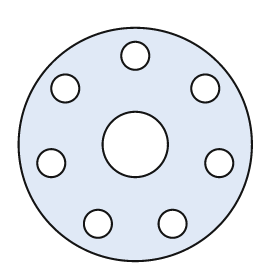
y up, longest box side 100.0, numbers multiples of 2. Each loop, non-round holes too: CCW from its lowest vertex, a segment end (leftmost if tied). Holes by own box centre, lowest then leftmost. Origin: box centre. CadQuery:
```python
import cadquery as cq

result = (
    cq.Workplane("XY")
    .moveTo(0.0, 0.0)
    .circle(50.0)
    .moveTo(-16.0, -34.0)
    .circle(6.0)
    .moveTo(16.0, -34.0)
    .circle(6.0)
    .moveTo(-36.0, -8.0)
    .circle(6.0)
    .moveTo(36.0, -8.0)
    .circle(6.0)
    .moveTo(0.0, 0.0)
    .circle(14.0)
    .moveTo(-30.0, 24.0)
    .circle(6.0)
    .moveTo(30.0, 24.0)
    .circle(6.0)
    .moveTo(0.0, 38.0)
    .circle(6.0)
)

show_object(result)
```